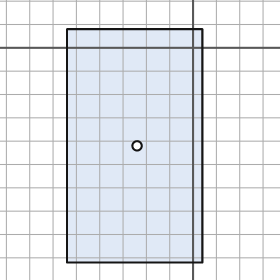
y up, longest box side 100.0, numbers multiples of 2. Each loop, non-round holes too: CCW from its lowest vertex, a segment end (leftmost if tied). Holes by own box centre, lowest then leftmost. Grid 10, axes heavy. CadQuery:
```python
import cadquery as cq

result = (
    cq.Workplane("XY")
    .moveTo(-54.0, -92.0)
    .lineTo(4.0, -92.0)
    .lineTo(4.0, 8.0)
    .lineTo(-54.0, 8.0)
    .close()
    .moveTo(-24.0, -42.0)
    .circle(2.0)
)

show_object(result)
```